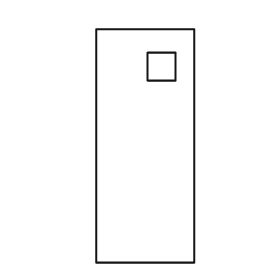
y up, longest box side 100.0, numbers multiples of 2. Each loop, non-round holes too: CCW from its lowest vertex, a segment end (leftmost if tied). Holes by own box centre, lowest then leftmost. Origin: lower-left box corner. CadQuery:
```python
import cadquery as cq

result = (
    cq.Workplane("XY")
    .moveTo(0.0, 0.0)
    .lineTo(42.0, 0.0)
    .lineTo(42.0, 100.0)
    .lineTo(0.0, 100.0)
    .close()
    .moveTo(22.0, 78.0)
    .lineTo(34.0, 78.0)
    .lineTo(34.0, 90.0)
    .lineTo(22.0, 90.0)
    .close()
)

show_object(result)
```